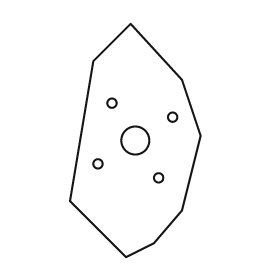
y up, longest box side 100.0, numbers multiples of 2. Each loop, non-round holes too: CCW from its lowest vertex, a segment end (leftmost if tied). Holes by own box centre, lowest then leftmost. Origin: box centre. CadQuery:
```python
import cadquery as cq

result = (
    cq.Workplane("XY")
    .moveTo(-4.0, -50.0)
    .lineTo(8.0, -44.0)
    .lineTo(20.0, -30.0)
    .lineTo(28.0, 2.0)
    .lineTo(20.0, 26.0)
    .lineTo(-2.0, 50.0)
    .lineTo(-18.0, 34.0)
    .lineTo(-28.0, -26.0)
    .close()
    .moveTo(10.0, -16.0)
    .circle(2.0)
    .moveTo(-16.0, -10.0)
    .circle(2.0)
    .moveTo(0.0, 0.0)
    .circle(6.0)
    .moveTo(16.0, 10.0)
    .circle(2.0)
    .moveTo(-10.0, 16.0)
    .circle(2.0)
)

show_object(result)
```